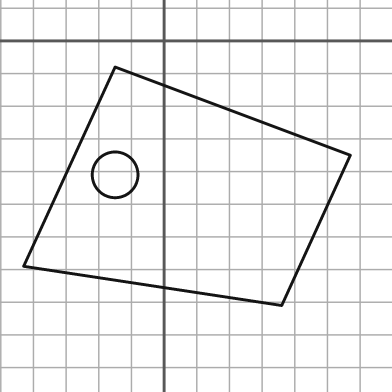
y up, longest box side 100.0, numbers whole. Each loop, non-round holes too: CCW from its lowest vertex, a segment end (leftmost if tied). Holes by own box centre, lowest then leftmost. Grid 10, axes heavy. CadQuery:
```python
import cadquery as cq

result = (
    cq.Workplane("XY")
    .moveTo(36.0, -81.0)
    .lineTo(57.0, -35.0)
    .lineTo(-15.0, -8.0)
    .lineTo(-43.0, -69.0)
    .close()
    .moveTo(-15.0, -41.0)
    .circle(7.0)
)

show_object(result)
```